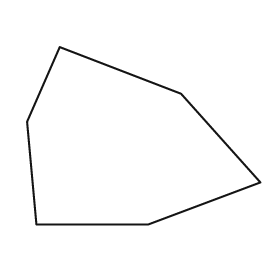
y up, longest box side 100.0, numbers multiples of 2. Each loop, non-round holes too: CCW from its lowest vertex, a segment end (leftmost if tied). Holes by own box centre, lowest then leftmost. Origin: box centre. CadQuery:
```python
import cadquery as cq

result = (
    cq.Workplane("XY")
    .moveTo(-46.0, -38.0)
    .lineTo(2.0, -38.0)
    .lineTo(50.0, -20.0)
    .lineTo(16.0, 18.0)
    .lineTo(-36.0, 38.0)
    .lineTo(-50.0, 6.0)
    .close()
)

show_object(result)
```